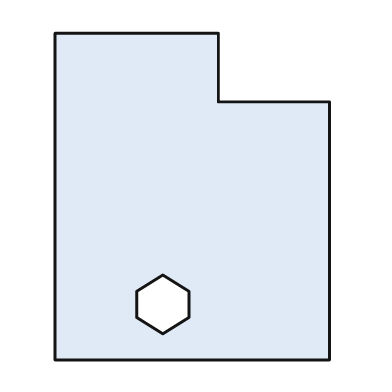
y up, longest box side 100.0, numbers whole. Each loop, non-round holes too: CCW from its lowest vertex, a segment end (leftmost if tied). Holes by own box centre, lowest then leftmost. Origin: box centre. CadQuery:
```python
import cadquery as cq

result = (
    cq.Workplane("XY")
    .moveTo(-42.0, -50.0)
    .lineTo(42.0, -50.0)
    .lineTo(42.0, 29.0)
    .lineTo(8.0, 29.0)
    .lineTo(8.0, 50.0)
    .lineTo(-42.0, 50.0)
    .close()
    .moveTo(-9.0, -42.0)
    .lineTo(-1.0, -37.0)
    .lineTo(-1.0, -29.0)
    .lineTo(-9.0, -24.0)
    .lineTo(-17.0, -29.0)
    .lineTo(-17.0, -37.0)
    .close()
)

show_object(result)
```